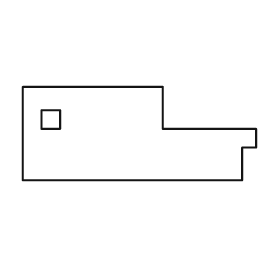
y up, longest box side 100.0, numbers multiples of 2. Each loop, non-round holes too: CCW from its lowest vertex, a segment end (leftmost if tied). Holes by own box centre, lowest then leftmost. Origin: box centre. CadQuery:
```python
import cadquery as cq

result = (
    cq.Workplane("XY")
    .moveTo(-50.0, -20.0)
    .lineTo(44.0, -20.0)
    .lineTo(44.0, -6.0)
    .lineTo(50.0, -6.0)
    .lineTo(50.0, 2.0)
    .lineTo(10.0, 2.0)
    .lineTo(10.0, 20.0)
    .lineTo(-50.0, 20.0)
    .close()
    .moveTo(-42.0, 2.0)
    .lineTo(-34.0, 2.0)
    .lineTo(-34.0, 10.0)
    .lineTo(-42.0, 10.0)
    .close()
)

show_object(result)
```